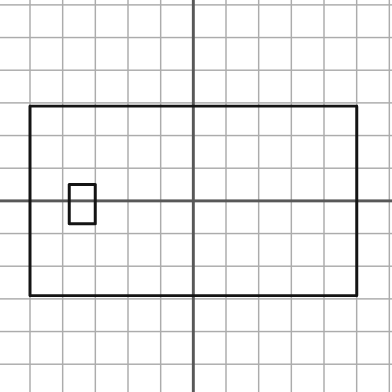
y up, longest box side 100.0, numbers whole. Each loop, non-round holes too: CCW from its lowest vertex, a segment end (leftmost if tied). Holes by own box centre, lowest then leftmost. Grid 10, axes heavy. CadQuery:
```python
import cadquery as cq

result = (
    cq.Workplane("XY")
    .moveTo(-50.0, -29.0)
    .lineTo(50.0, -29.0)
    .lineTo(50.0, 29.0)
    .lineTo(-50.0, 29.0)
    .close()
    .moveTo(-38.0, -7.0)
    .lineTo(-30.0, -7.0)
    .lineTo(-30.0, 5.0)
    .lineTo(-38.0, 5.0)
    .close()
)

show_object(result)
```